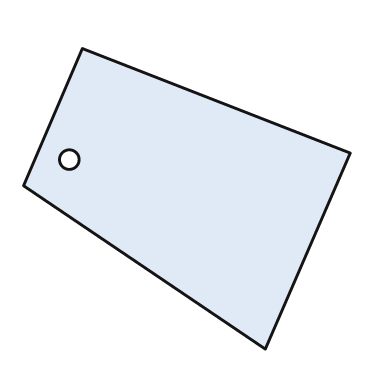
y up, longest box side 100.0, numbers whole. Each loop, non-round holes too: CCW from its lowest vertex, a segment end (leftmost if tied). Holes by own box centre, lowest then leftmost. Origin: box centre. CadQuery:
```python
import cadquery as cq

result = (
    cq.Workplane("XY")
    .moveTo(24.0, -46.0)
    .lineTo(50.0, 14.0)
    .lineTo(-32.0, 46.0)
    .lineTo(-50.0, 4.0)
    .close()
    .moveTo(-36.0, 12.0)
    .circle(3.0)
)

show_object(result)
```